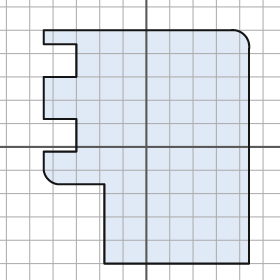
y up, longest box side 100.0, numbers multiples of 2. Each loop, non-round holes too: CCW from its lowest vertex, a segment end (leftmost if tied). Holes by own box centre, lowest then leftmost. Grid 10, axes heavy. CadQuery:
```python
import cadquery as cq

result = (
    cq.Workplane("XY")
    .moveTo(-18.0, -50.0)
    .lineTo(44.0, -50.0)
    .lineTo(44.0, 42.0)
    .threePointArc((42.0, 48.0), (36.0, 50.0))
    .lineTo(-44.0, 50.0)
    .lineTo(-44.0, 44.0)
    .lineTo(-30.0, 44.0)
    .lineTo(-30.0, 30.0)
    .lineTo(-44.0, 30.0)
    .lineTo(-44.0, 12.0)
    .lineTo(-30.0, 12.0)
    .lineTo(-30.0, -2.0)
    .lineTo(-44.0, -2.0)
    .lineTo(-44.0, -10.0)
    .threePointArc((-42.0, -14.0), (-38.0, -16.0))
    .lineTo(-18.0, -16.0)
    .close()
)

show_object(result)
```